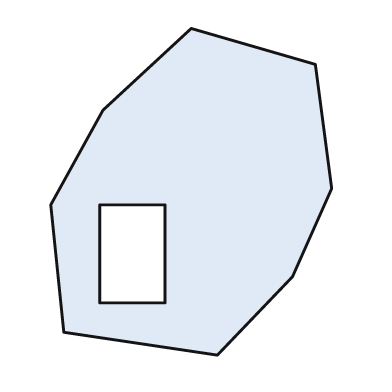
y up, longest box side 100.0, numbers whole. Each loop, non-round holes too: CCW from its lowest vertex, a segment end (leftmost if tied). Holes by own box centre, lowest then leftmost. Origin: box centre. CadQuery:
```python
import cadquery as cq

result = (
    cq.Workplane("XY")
    .moveTo(8.0, -50.0)
    .lineTo(31.0, -26.0)
    .lineTo(43.0, 1.0)
    .lineTo(38.0, 39.0)
    .lineTo(0.0, 50.0)
    .lineTo(-27.0, 25.0)
    .lineTo(-43.0, -4.0)
    .lineTo(-39.0, -43.0)
    .close()
    .moveTo(-28.0, -34.0)
    .lineTo(-8.0, -34.0)
    .lineTo(-8.0, -4.0)
    .lineTo(-28.0, -4.0)
    .close()
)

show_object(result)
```